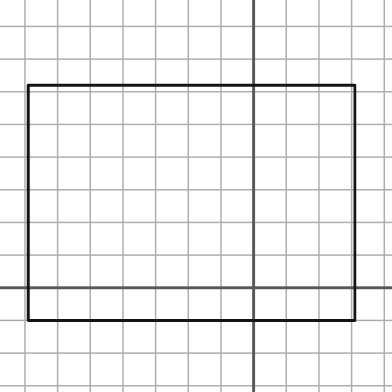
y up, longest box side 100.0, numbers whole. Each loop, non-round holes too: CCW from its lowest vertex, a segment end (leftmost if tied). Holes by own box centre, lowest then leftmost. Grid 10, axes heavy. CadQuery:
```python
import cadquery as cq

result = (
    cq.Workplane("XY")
    .moveTo(-69.0, -10.0)
    .lineTo(31.0, -10.0)
    .lineTo(31.0, 62.0)
    .lineTo(-69.0, 62.0)
    .close()
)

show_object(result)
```